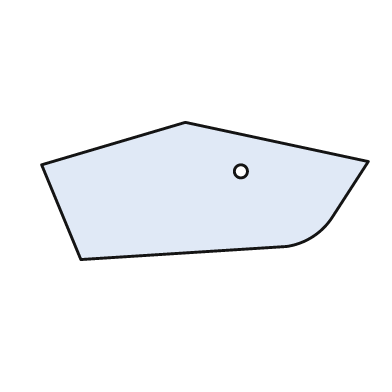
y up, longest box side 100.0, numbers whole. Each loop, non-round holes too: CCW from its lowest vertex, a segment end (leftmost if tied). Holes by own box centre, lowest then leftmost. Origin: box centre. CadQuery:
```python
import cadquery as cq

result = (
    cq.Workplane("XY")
    .moveTo(-38.0, -21.0)
    .lineTo(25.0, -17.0)
    .threePointArc((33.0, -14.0), (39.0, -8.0))
    .lineTo(50.0, 9.0)
    .lineTo(-6.0, 21.0)
    .lineTo(-50.0, 8.0)
    .close()
    .moveTo(11.0, 6.0)
    .circle(2.0)
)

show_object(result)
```